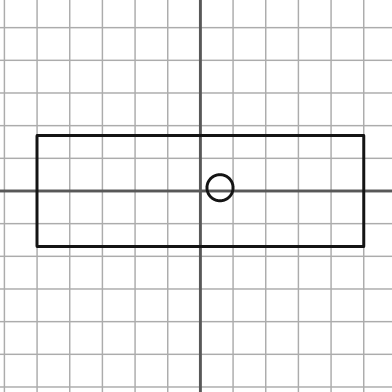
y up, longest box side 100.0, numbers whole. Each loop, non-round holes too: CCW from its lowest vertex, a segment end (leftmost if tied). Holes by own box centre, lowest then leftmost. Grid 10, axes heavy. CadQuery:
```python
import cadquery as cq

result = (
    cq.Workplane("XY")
    .moveTo(-50.0, -17.0)
    .lineTo(50.0, -17.0)
    .lineTo(50.0, 17.0)
    .lineTo(-50.0, 17.0)
    .close()
    .moveTo(6.0, 1.0)
    .circle(4.0)
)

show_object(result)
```